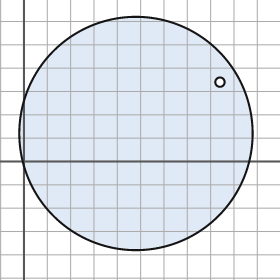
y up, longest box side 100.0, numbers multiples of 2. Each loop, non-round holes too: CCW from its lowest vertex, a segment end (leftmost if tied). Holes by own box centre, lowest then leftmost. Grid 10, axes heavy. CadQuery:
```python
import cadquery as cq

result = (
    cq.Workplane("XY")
    .moveTo(48.0, 12.0)
    .circle(50.0)
    .moveTo(84.0, 34.0)
    .circle(2.0)
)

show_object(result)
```